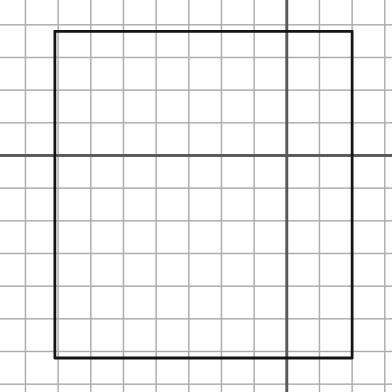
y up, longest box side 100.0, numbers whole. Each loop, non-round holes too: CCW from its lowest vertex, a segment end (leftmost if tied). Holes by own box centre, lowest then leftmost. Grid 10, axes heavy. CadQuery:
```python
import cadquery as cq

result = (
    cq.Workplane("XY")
    .moveTo(-71.0, -62.0)
    .lineTo(20.0, -62.0)
    .lineTo(20.0, 38.0)
    .lineTo(-71.0, 38.0)
    .close()
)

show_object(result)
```